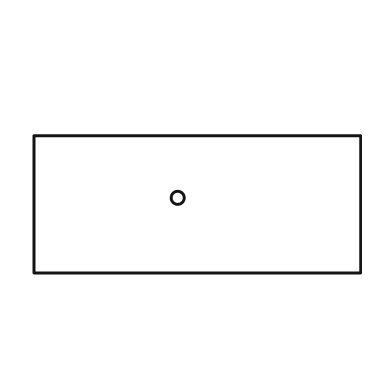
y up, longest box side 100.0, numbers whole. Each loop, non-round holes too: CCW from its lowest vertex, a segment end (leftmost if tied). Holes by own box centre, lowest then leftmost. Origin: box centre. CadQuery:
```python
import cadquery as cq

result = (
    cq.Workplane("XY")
    .moveTo(-50.0, -21.0)
    .lineTo(50.0, -21.0)
    .lineTo(50.0, 21.0)
    .lineTo(-50.0, 21.0)
    .close()
    .moveTo(-6.0, 2.0)
    .circle(2.0)
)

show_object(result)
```